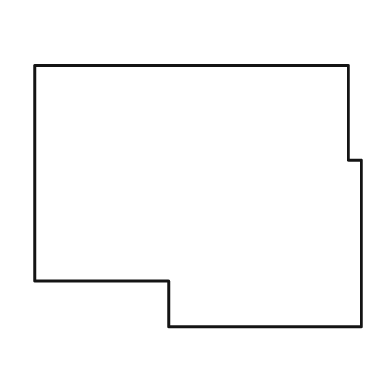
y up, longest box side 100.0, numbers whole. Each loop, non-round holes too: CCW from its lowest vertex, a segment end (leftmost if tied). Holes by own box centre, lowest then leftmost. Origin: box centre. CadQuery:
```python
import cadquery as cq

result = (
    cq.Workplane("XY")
    .moveTo(-9.0, -40.0)
    .lineTo(50.0, -40.0)
    .lineTo(50.0, 11.0)
    .lineTo(46.0, 11.0)
    .lineTo(46.0, 40.0)
    .lineTo(-50.0, 40.0)
    .lineTo(-50.0, -26.0)
    .lineTo(-9.0, -26.0)
    .close()
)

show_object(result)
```